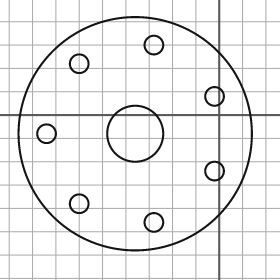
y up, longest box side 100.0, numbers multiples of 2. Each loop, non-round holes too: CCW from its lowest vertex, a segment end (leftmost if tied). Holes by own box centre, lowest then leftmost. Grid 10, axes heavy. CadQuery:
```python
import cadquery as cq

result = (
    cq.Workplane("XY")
    .moveTo(-36.0, -8.0)
    .circle(50.0)
    .moveTo(-28.0, -46.0)
    .circle(4.0)
    .moveTo(-60.0, -38.0)
    .circle(4.0)
    .moveTo(-2.0, -24.0)
    .circle(4.0)
    .moveTo(-74.0, -8.0)
    .circle(4.0)
    .moveTo(-36.0, -8.0)
    .circle(12.0)
    .moveTo(-2.0, 8.0)
    .circle(4.0)
    .moveTo(-60.0, 22.0)
    .circle(4.0)
    .moveTo(-28.0, 30.0)
    .circle(4.0)
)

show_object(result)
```